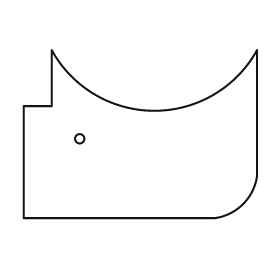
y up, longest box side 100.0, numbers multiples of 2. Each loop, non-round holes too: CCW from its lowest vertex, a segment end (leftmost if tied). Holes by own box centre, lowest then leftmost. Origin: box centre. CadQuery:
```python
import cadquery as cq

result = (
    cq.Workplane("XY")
    .moveTo(-50.0, -36.0)
    .lineTo(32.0, -36.0)
    .threePointArc((44.0, -30.0), (50.0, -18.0))
    .lineTo(50.0, 36.0)
    .threePointArc((6.0, 10.0), (-38.0, 36.0))
    .lineTo(-38.0, 12.0)
    .lineTo(-50.0, 12.0)
    .close()
    .moveTo(-26.0, -2.0)
    .circle(2.0)
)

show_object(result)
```